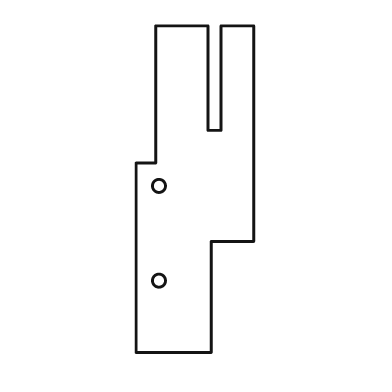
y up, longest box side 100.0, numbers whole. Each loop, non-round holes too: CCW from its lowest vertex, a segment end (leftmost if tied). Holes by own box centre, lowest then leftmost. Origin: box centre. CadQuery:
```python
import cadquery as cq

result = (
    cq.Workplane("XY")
    .moveTo(-18.0, -50.0)
    .lineTo(5.0, -50.0)
    .lineTo(5.0, -16.0)
    .lineTo(18.0, -16.0)
    .lineTo(18.0, 50.0)
    .lineTo(8.0, 50.0)
    .lineTo(8.0, 18.0)
    .lineTo(4.0, 18.0)
    .lineTo(4.0, 50.0)
    .lineTo(-12.0, 50.0)
    .lineTo(-12.0, 8.0)
    .lineTo(-18.0, 8.0)
    .close()
    .moveTo(-11.0, -28.0)
    .circle(2.0)
    .moveTo(-11.0, 1.0)
    .circle(2.0)
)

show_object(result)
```